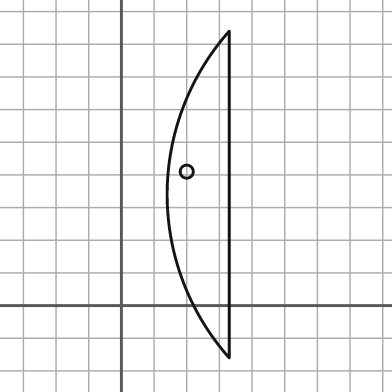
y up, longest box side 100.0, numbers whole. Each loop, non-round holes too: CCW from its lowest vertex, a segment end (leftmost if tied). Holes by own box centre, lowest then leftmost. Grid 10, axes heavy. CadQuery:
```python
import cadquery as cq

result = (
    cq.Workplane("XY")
    .moveTo(33.0, -16.0)
    .lineTo(33.0, 84.0)
    .threePointArc((14.0, 34.0), (33.0, -16.0))
    .close()
    .moveTo(20.0, 41.0)
    .circle(2.0)
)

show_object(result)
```